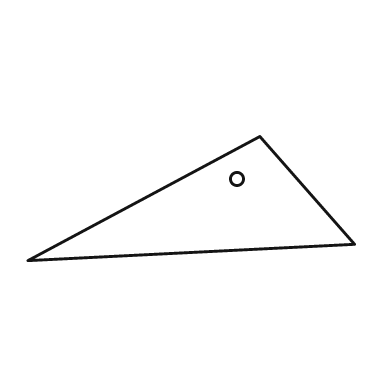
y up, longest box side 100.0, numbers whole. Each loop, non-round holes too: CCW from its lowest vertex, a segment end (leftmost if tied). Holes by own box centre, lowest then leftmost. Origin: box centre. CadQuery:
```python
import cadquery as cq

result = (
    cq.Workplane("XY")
    .moveTo(-50.0, -19.0)
    .lineTo(50.0, -14.0)
    .lineTo(21.0, 19.0)
    .close()
    .moveTo(14.0, 6.0)
    .circle(2.0)
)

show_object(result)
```